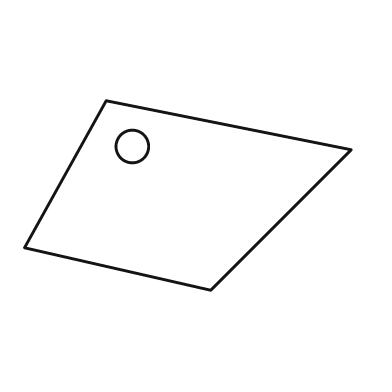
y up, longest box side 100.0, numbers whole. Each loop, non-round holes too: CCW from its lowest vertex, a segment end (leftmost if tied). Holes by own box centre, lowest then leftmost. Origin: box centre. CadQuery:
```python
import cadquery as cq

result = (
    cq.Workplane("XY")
    .moveTo(7.0, -29.0)
    .lineTo(50.0, 14.0)
    .lineTo(-25.0, 29.0)
    .lineTo(-50.0, -16.0)
    .close()
    .moveTo(-17.0, 15.0)
    .circle(5.0)
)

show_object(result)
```